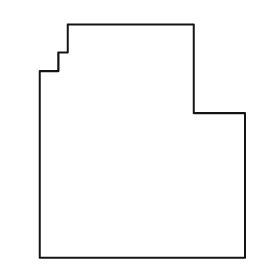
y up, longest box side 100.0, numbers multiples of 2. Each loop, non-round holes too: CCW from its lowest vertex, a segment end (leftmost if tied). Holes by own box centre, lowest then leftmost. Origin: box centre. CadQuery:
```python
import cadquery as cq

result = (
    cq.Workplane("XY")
    .moveTo(-44.0, -50.0)
    .lineTo(44.0, -50.0)
    .lineTo(44.0, 12.0)
    .lineTo(22.0, 12.0)
    .lineTo(22.0, 50.0)
    .lineTo(-32.0, 50.0)
    .lineTo(-32.0, 38.0)
    .lineTo(-36.0, 38.0)
    .lineTo(-36.0, 30.0)
    .lineTo(-44.0, 30.0)
    .close()
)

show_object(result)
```